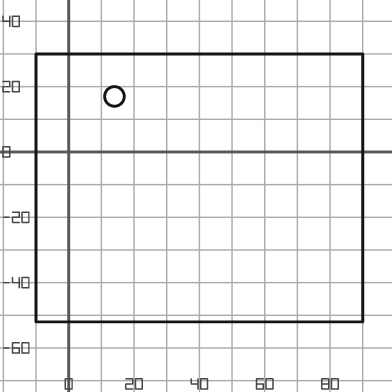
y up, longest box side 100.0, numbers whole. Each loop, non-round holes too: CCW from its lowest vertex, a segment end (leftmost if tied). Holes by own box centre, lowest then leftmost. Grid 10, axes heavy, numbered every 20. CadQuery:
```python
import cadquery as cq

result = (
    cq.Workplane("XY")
    .moveTo(-10.0, -52.0)
    .lineTo(90.0, -52.0)
    .lineTo(90.0, 30.0)
    .lineTo(-10.0, 30.0)
    .close()
    .moveTo(14.0, 17.0)
    .circle(3.0)
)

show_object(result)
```